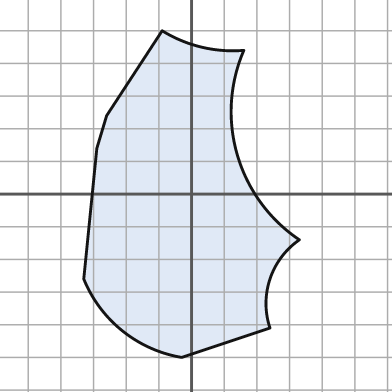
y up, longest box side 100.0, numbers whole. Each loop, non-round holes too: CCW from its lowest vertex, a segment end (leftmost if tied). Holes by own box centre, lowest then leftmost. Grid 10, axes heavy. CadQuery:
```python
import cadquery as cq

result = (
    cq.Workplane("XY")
    .moveTo(-3.0, -50.0)
    .lineTo(24.0, -41.0)
    .threePointArc((24.0, -26.0), (33.0, -14.0))
    .threePointArc((14.0, 12.0), (16.0, 44.0))
    .threePointArc((3.0, 45.0), (-9.0, 50.0))
    .lineTo(-26.0, 24.0)
    .lineTo(-29.0, 14.0)
    .lineTo(-33.0, -26.0)
    .threePointArc((-21.0, -42.0), (-3.0, -50.0))
    .close()
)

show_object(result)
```